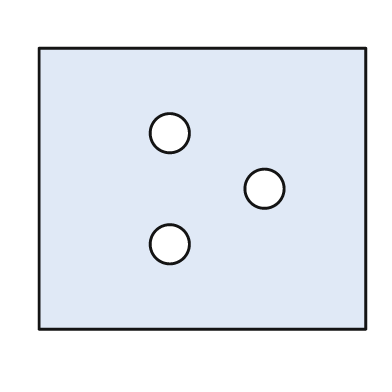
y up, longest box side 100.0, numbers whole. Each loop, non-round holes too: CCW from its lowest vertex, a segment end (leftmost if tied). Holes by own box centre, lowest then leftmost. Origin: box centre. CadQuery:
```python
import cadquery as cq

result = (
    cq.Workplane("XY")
    .moveTo(-50.0, -43.0)
    .lineTo(50.0, -43.0)
    .lineTo(50.0, 43.0)
    .lineTo(-50.0, 43.0)
    .close()
    .moveTo(-10.0, -17.0)
    .circle(6.0)
    .moveTo(19.0, 0.0)
    .circle(6.0)
    .moveTo(-10.0, 17.0)
    .circle(6.0)
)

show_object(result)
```